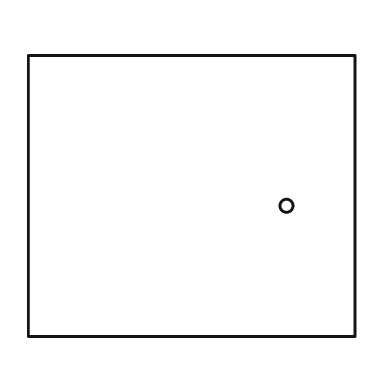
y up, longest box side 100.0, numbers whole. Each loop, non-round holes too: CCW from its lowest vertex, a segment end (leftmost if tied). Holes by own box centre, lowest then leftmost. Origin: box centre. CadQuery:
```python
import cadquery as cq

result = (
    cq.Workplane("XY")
    .moveTo(-50.0, -43.0)
    .lineTo(50.0, -43.0)
    .lineTo(50.0, 43.0)
    .lineTo(-50.0, 43.0)
    .close()
    .moveTo(29.0, -3.0)
    .circle(2.0)
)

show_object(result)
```